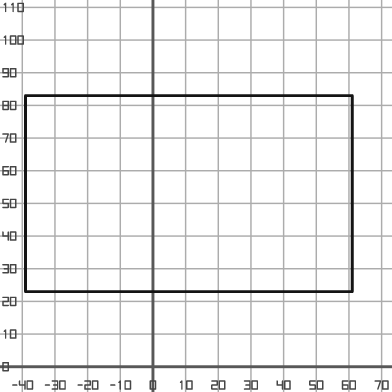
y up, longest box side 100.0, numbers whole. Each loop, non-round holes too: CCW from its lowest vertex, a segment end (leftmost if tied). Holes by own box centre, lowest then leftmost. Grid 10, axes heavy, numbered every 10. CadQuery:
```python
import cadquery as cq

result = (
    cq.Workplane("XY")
    .moveTo(-39.0, 23.0)
    .lineTo(61.0, 23.0)
    .lineTo(61.0, 83.0)
    .lineTo(-39.0, 83.0)
    .close()
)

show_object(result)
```